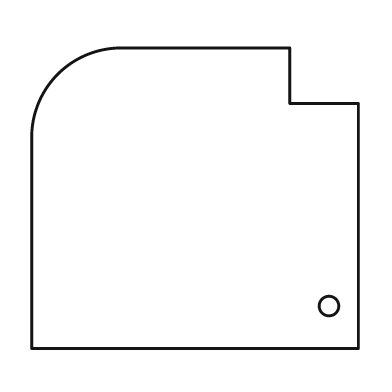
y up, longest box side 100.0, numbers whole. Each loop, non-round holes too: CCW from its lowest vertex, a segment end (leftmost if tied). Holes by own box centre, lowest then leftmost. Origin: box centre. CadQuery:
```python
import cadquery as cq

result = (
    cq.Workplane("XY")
    .moveTo(-50.0, -46.0)
    .lineTo(50.0, -46.0)
    .lineTo(50.0, 29.0)
    .lineTo(29.0, 29.0)
    .lineTo(29.0, 46.0)
    .lineTo(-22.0, 46.0)
    .threePointArc((-42.0, 38.0), (-50.0, 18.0))
    .close()
    .moveTo(41.0, -33.0)
    .circle(3.0)
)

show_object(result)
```